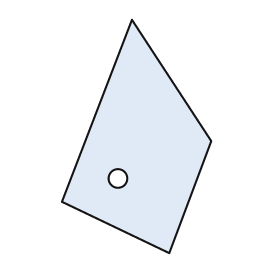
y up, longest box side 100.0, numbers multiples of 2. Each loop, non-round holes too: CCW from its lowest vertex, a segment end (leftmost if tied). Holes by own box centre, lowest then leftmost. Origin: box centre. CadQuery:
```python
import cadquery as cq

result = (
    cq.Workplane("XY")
    .moveTo(14.0, -50.0)
    .lineTo(32.0, -2.0)
    .lineTo(-2.0, 50.0)
    .lineTo(-32.0, -28.0)
    .close()
    .moveTo(-8.0, -18.0)
    .circle(4.0)
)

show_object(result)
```